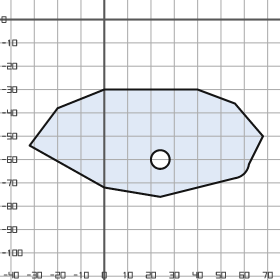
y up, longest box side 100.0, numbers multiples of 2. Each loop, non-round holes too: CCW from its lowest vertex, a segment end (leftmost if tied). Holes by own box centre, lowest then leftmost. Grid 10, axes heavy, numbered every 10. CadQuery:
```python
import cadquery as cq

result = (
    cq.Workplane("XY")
    .moveTo(24.0, -76.0)
    .lineTo(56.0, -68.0)
    .threePointArc((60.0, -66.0), (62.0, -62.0))
    .lineTo(68.0, -50.0)
    .lineTo(56.0, -36.0)
    .lineTo(40.0, -30.0)
    .lineTo(0.0, -30.0)
    .lineTo(-20.0, -38.0)
    .lineTo(-32.0, -54.0)
    .lineTo(0.0, -72.0)
    .close()
    .moveTo(24.0, -60.0)
    .circle(4.0)
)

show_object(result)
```